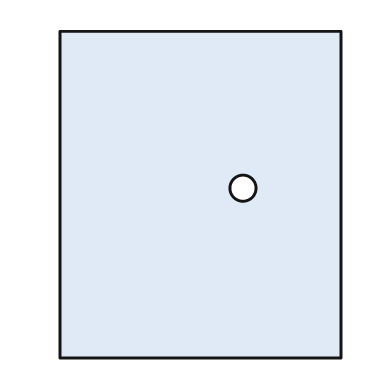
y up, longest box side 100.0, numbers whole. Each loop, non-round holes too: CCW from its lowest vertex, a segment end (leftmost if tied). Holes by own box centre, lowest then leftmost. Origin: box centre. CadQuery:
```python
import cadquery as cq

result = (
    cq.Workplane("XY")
    .moveTo(-43.0, -50.0)
    .lineTo(43.0, -50.0)
    .lineTo(43.0, 50.0)
    .lineTo(-43.0, 50.0)
    .close()
    .moveTo(13.0, 2.0)
    .circle(4.0)
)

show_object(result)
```